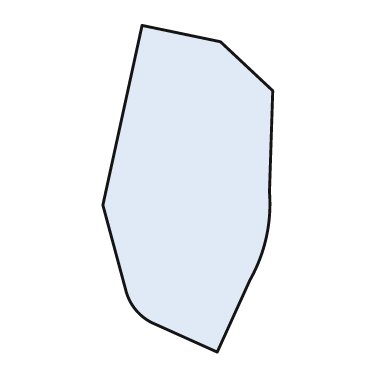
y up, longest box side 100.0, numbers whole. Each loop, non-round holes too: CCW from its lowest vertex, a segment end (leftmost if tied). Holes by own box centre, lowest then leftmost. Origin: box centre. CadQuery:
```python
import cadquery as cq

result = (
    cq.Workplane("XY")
    .moveTo(9.0, -50.0)
    .lineTo(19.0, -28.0)
    .threePointArc((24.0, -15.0), (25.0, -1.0))
    .lineTo(26.0, 30.0)
    .lineTo(10.0, 45.0)
    .lineTo(-14.0, 50.0)
    .lineTo(-26.0, -5.0)
    .lineTo(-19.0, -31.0)
    .threePointArc((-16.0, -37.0), (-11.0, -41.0))
    .close()
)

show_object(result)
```